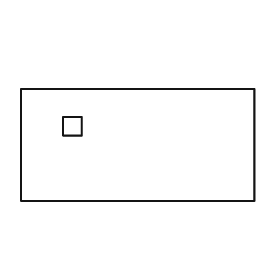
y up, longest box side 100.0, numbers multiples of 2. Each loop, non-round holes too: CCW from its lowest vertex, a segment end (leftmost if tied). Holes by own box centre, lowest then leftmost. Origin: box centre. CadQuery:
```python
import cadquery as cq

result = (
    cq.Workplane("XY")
    .moveTo(-50.0, -24.0)
    .lineTo(50.0, -24.0)
    .lineTo(50.0, 24.0)
    .lineTo(-50.0, 24.0)
    .close()
    .moveTo(-32.0, 4.0)
    .lineTo(-24.0, 4.0)
    .lineTo(-24.0, 12.0)
    .lineTo(-32.0, 12.0)
    .close()
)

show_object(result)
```